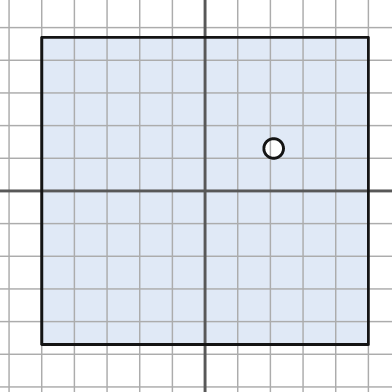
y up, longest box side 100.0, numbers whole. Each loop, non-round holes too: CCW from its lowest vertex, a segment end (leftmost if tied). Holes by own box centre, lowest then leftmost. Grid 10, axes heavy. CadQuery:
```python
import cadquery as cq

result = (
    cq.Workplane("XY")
    .moveTo(-50.0, -47.0)
    .lineTo(50.0, -47.0)
    .lineTo(50.0, 47.0)
    .lineTo(-50.0, 47.0)
    .close()
    .moveTo(21.0, 13.0)
    .circle(3.0)
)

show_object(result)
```